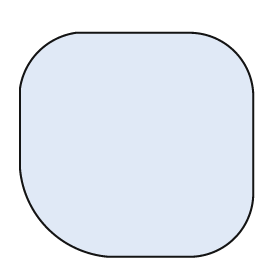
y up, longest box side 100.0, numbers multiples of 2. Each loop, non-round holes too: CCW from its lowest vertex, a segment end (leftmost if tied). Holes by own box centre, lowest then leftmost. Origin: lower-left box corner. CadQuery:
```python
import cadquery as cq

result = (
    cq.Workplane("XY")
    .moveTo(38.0, 0.0)
    .lineTo(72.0, 0.0)
    .threePointArc((92.0, 8.0), (100.0, 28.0))
    .lineTo(100.0, 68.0)
    .threePointArc((92.0, 88.0), (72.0, 96.0))
    .lineTo(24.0, 96.0)
    .threePointArc((8.0, 88.0), (0.0, 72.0))
    .lineTo(0.0, 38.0)
    .threePointArc((12.0, 12.0), (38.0, 0.0))
    .close()
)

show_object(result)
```